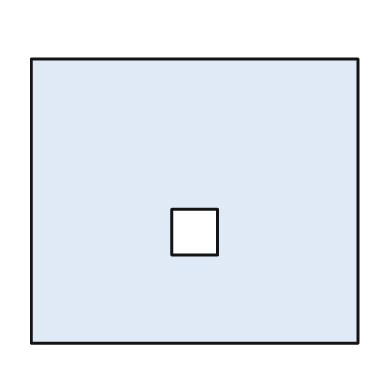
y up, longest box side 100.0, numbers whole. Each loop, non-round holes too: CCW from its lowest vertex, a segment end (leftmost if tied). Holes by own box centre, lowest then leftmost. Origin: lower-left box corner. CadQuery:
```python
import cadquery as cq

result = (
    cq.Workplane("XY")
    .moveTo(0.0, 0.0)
    .lineTo(100.0, 0.0)
    .lineTo(100.0, 87.0)
    .lineTo(0.0, 87.0)
    .close()
    .moveTo(43.0, 27.0)
    .lineTo(57.0, 27.0)
    .lineTo(57.0, 41.0)
    .lineTo(43.0, 41.0)
    .close()
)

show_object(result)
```